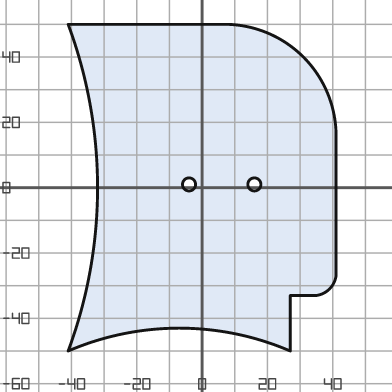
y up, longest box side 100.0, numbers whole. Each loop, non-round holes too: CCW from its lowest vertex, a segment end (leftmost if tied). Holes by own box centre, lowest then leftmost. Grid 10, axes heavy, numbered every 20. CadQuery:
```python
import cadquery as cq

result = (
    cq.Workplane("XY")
    .moveTo(-41.0, -50.0)
    .threePointArc((-7.0, -43.0), (27.0, -50.0))
    .lineTo(27.0, -33.0)
    .lineTo(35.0, -33.0)
    .threePointArc((39.0, -31.0), (41.0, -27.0))
    .lineTo(41.0, 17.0)
    .threePointArc((31.0, 40.0), (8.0, 50.0))
    .lineTo(-41.0, 50.0)
    .threePointArc((-32.0, 0.0), (-41.0, -50.0))
    .close()
    .moveTo(-4.0, 1.0)
    .circle(2.0)
    .moveTo(16.0, 1.0)
    .circle(2.0)
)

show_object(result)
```